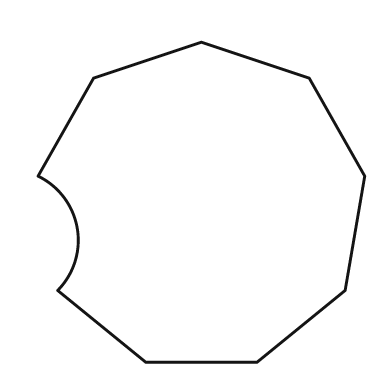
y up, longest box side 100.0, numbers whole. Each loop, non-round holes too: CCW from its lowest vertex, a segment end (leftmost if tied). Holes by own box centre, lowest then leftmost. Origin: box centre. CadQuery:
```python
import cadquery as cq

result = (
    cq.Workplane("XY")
    .moveTo(-17.0, -49.0)
    .lineTo(17.0, -49.0)
    .lineTo(44.0, -27.0)
    .lineTo(50.0, 8.0)
    .lineTo(33.0, 38.0)
    .lineTo(0.0, 49.0)
    .lineTo(-33.0, 38.0)
    .lineTo(-50.0, 8.0)
    .threePointArc((-38.0, -8.0), (-44.0, -27.0))
    .close()
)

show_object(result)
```